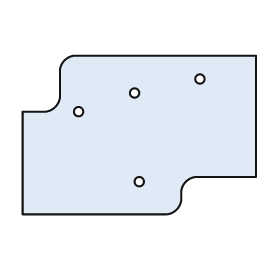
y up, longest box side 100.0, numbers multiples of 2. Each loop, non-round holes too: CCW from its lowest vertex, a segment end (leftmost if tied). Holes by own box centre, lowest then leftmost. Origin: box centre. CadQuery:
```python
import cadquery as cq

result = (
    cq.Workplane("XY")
    .moveTo(-50.0, -34.0)
    .lineTo(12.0, -34.0)
    .threePointArc((16.0, -32.0), (18.0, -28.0))
    .lineTo(18.0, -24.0)
    .threePointArc((20.0, -20.0), (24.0, -18.0))
    .lineTo(50.0, -18.0)
    .lineTo(50.0, 34.0)
    .lineTo(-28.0, 34.0)
    .threePointArc((-32.0, 32.0), (-34.0, 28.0))
    .lineTo(-34.0, 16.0)
    .threePointArc((-36.0, 12.0), (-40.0, 10.0))
    .lineTo(-50.0, 10.0)
    .close()
    .moveTo(0.0, -20.0)
    .circle(2.0)
    .moveTo(-26.0, 10.0)
    .circle(2.0)
    .moveTo(-2.0, 18.0)
    .circle(2.0)
    .moveTo(26.0, 24.0)
    .circle(2.0)
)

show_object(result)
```